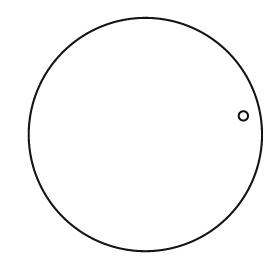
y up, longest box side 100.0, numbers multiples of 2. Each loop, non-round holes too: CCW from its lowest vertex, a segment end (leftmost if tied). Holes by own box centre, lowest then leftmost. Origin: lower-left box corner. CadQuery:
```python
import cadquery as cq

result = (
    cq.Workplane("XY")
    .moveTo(50.0, 50.0)
    .circle(50.0)
    .moveTo(92.0, 58.0)
    .circle(2.0)
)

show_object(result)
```